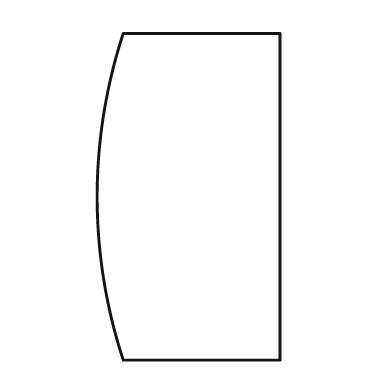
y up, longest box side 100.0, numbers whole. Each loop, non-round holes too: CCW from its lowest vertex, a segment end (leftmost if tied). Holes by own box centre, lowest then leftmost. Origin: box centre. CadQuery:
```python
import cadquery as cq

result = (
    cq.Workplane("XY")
    .moveTo(-20.0, -50.0)
    .lineTo(28.0, -50.0)
    .lineTo(28.0, 50.0)
    .lineTo(-20.0, 50.0)
    .threePointArc((-28.0, 0.0), (-20.0, -50.0))
    .close()
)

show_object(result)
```